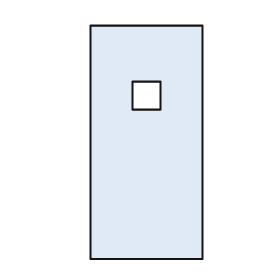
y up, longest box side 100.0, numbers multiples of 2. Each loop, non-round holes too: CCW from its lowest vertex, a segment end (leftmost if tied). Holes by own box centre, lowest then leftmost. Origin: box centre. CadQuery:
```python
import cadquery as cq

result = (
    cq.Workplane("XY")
    .moveTo(-24.0, -50.0)
    .lineTo(24.0, -50.0)
    .lineTo(24.0, 50.0)
    .lineTo(-24.0, 50.0)
    .close()
    .moveTo(-6.0, 14.0)
    .lineTo(6.0, 14.0)
    .lineTo(6.0, 26.0)
    .lineTo(-6.0, 26.0)
    .close()
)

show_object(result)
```